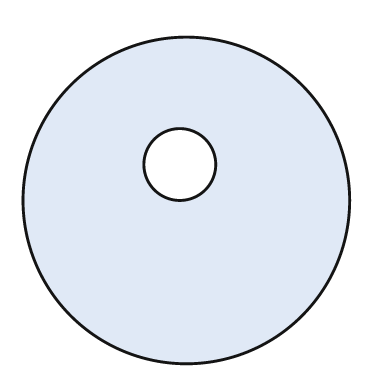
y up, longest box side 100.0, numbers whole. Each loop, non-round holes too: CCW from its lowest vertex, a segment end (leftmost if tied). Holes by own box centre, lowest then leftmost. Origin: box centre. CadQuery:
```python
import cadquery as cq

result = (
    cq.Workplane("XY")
    .moveTo(0.0, 0.0)
    .circle(50.0)
    .moveTo(-2.0, 11.0)
    .circle(11.0)
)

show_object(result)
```